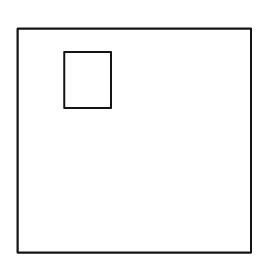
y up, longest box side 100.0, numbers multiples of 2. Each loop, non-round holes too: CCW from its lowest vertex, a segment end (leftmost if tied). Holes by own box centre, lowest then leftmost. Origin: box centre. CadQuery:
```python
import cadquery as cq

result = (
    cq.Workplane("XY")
    .moveTo(-50.0, -48.0)
    .lineTo(50.0, -48.0)
    .lineTo(50.0, 48.0)
    .lineTo(-50.0, 48.0)
    .close()
    .moveTo(-30.0, 14.0)
    .lineTo(-10.0, 14.0)
    .lineTo(-10.0, 38.0)
    .lineTo(-30.0, 38.0)
    .close()
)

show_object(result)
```